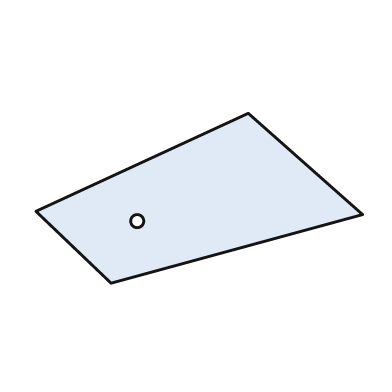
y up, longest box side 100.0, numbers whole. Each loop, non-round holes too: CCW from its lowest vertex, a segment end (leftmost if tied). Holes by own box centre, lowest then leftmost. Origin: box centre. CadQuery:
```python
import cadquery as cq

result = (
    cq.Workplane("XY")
    .moveTo(-27.0, -26.0)
    .lineTo(50.0, -5.0)
    .lineTo(15.0, 26.0)
    .lineTo(-50.0, -4.0)
    .close()
    .moveTo(-19.0, -7.0)
    .circle(2.0)
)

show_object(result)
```